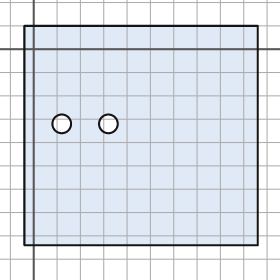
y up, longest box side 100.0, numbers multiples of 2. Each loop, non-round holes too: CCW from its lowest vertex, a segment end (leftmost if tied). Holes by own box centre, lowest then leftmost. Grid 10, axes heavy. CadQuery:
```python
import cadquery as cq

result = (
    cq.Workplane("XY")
    .moveTo(-4.0, -84.0)
    .lineTo(96.0, -84.0)
    .lineTo(96.0, 10.0)
    .lineTo(-4.0, 10.0)
    .close()
    .moveTo(12.0, -32.0)
    .circle(4.0)
    .moveTo(32.0, -32.0)
    .circle(4.0)
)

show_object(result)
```